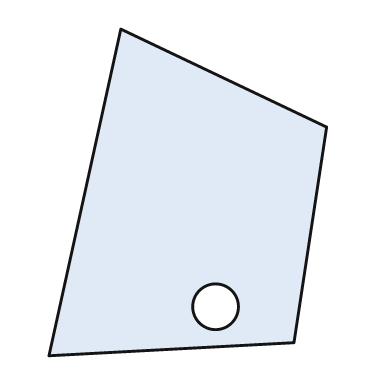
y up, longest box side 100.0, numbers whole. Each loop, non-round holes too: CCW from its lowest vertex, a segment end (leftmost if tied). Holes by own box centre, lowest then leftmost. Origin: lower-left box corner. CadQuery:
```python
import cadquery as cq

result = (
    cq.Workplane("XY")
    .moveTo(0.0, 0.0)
    .lineTo(75.0, 4.0)
    .lineTo(85.0, 70.0)
    .lineTo(22.0, 100.0)
    .close()
    .moveTo(51.0, 15.0)
    .circle(7.0)
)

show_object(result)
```